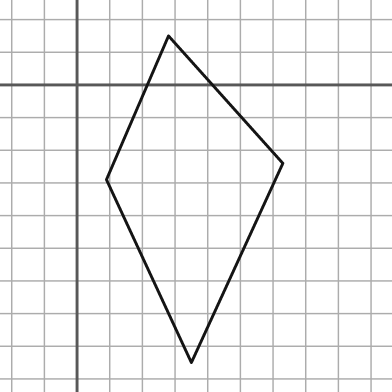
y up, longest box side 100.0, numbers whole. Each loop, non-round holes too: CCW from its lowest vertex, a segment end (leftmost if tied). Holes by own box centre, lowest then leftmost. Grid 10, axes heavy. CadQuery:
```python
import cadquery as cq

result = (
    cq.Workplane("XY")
    .moveTo(35.0, -85.0)
    .lineTo(63.0, -24.0)
    .lineTo(28.0, 15.0)
    .lineTo(9.0, -29.0)
    .close()
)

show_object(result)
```